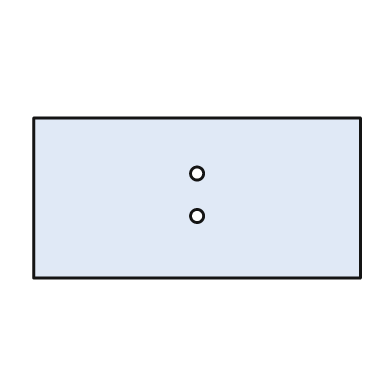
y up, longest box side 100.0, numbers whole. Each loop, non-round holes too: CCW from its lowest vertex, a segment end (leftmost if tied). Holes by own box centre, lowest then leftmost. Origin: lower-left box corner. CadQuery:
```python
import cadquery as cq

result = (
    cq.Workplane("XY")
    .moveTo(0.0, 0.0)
    .lineTo(100.0, 0.0)
    .lineTo(100.0, 49.0)
    .lineTo(0.0, 49.0)
    .close()
    .moveTo(50.0, 19.0)
    .circle(2.0)
    .moveTo(50.0, 32.0)
    .circle(2.0)
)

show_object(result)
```